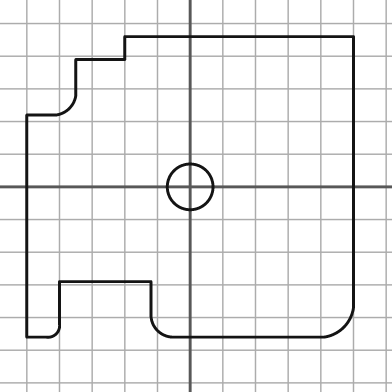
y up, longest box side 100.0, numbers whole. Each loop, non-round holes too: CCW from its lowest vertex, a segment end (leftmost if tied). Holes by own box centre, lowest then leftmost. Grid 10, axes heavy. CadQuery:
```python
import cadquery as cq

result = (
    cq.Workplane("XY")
    .moveTo(-50.0, -46.0)
    .lineTo(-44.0, -46.0)
    .threePointArc((-41.0, -45.0), (-40.0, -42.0))
    .lineTo(-40.0, -29.0)
    .lineTo(-12.0, -29.0)
    .lineTo(-12.0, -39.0)
    .threePointArc((-10.0, -44.0), (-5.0, -46.0))
    .lineTo(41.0, -46.0)
    .threePointArc((47.0, -43.0), (50.0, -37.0))
    .lineTo(50.0, 46.0)
    .lineTo(-20.0, 46.0)
    .lineTo(-20.0, 39.0)
    .lineTo(-35.0, 39.0)
    .lineTo(-35.0, 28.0)
    .threePointArc((-37.0, 24.0), (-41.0, 22.0))
    .lineTo(-50.0, 22.0)
    .close()
    .moveTo(0.0, 0.0)
    .circle(7.0)
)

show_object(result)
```